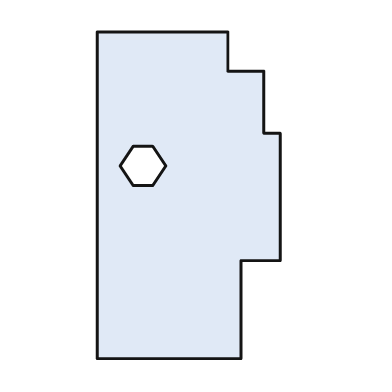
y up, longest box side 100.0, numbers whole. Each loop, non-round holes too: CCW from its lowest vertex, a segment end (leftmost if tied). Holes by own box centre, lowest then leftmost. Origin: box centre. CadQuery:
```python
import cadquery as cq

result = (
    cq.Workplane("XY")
    .moveTo(-28.0, -50.0)
    .lineTo(16.0, -50.0)
    .lineTo(16.0, -20.0)
    .lineTo(28.0, -20.0)
    .lineTo(28.0, 19.0)
    .lineTo(23.0, 19.0)
    .lineTo(23.0, 38.0)
    .lineTo(12.0, 38.0)
    .lineTo(12.0, 50.0)
    .lineTo(-28.0, 50.0)
    .close()
    .moveTo(-17.0, 3.0)
    .lineTo(-11.0, 3.0)
    .lineTo(-7.0, 9.0)
    .lineTo(-11.0, 15.0)
    .lineTo(-17.0, 15.0)
    .lineTo(-21.0, 9.0)
    .close()
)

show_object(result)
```